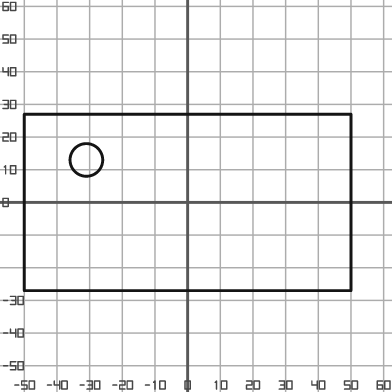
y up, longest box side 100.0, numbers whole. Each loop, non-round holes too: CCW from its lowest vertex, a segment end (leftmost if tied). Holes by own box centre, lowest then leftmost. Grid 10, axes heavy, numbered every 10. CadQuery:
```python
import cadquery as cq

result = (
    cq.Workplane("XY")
    .moveTo(-50.0, -27.0)
    .lineTo(50.0, -27.0)
    .lineTo(50.0, 27.0)
    .lineTo(-50.0, 27.0)
    .close()
    .moveTo(-31.0, 13.0)
    .circle(5.0)
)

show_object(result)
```